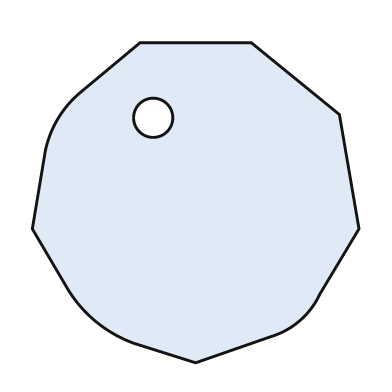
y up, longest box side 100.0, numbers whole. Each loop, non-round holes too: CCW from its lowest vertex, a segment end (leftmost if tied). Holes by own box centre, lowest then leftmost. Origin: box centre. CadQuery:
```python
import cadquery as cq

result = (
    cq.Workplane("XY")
    .moveTo(0.0, -49.0)
    .lineTo(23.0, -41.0)
    .threePointArc((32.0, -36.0), (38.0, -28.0))
    .lineTo(50.0, -8.0)
    .lineTo(44.0, 27.0)
    .lineTo(17.0, 49.0)
    .lineTo(-17.0, 49.0)
    .lineTo(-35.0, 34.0)
    .threePointArc((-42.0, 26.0), (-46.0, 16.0))
    .lineTo(-50.0, -8.0)
    .lineTo(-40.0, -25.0)
    .threePointArc((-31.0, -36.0), (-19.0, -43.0))
    .close()
    .moveTo(-13.0, 26.0)
    .circle(6.0)
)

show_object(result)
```